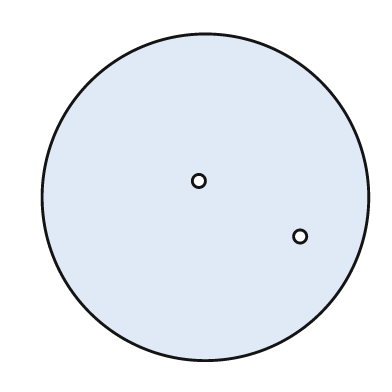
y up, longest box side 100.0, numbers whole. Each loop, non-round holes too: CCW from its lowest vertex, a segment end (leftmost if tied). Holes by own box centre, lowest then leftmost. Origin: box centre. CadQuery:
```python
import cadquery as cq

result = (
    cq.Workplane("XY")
    .moveTo(0.0, 0.0)
    .circle(50.0)
    .moveTo(29.0, -12.0)
    .circle(2.0)
    .moveTo(-2.0, 5.0)
    .circle(2.0)
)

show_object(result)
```